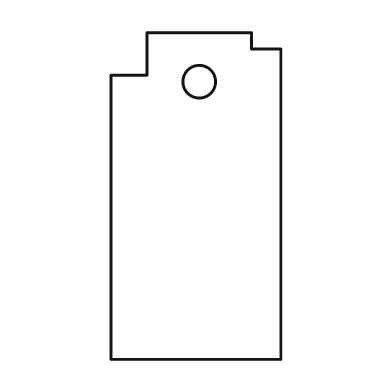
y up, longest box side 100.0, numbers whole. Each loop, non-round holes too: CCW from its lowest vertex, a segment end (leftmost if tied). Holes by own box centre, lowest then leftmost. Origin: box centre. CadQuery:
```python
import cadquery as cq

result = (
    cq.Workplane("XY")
    .moveTo(-26.0, -50.0)
    .lineTo(26.0, -50.0)
    .lineTo(26.0, 45.0)
    .lineTo(17.0, 45.0)
    .lineTo(17.0, 50.0)
    .lineTo(-15.0, 50.0)
    .lineTo(-15.0, 37.0)
    .lineTo(-26.0, 37.0)
    .close()
    .moveTo(1.0, 35.0)
    .circle(5.0)
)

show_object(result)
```